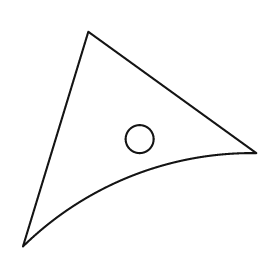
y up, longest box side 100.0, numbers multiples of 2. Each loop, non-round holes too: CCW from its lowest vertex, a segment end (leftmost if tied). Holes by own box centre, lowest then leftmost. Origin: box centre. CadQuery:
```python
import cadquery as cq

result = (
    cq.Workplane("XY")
    .moveTo(-50.0, -46.0)
    .threePointArc((-4.0, -16.0), (50.0, -6.0))
    .lineTo(-22.0, 46.0)
    .close()
    .moveTo(0.0, 0.0)
    .circle(6.0)
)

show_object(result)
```